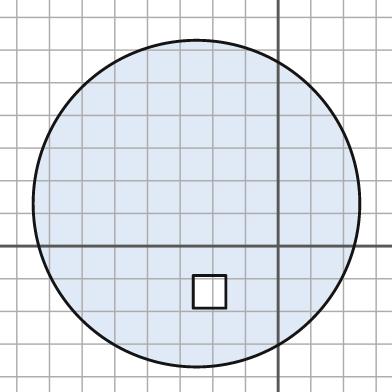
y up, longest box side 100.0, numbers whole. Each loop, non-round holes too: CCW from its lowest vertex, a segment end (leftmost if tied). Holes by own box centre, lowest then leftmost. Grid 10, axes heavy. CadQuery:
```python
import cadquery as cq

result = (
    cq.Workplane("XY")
    .moveTo(-25.0, 13.0)
    .circle(50.0)
    .moveTo(-26.0, -19.0)
    .lineTo(-16.0, -19.0)
    .lineTo(-16.0, -9.0)
    .lineTo(-26.0, -9.0)
    .close()
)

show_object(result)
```